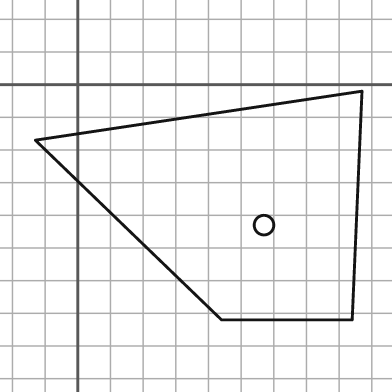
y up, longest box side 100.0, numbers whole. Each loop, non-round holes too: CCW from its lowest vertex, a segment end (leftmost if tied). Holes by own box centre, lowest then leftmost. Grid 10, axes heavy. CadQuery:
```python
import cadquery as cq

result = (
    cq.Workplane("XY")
    .moveTo(44.0, -72.0)
    .lineTo(84.0, -72.0)
    .lineTo(87.0, -2.0)
    .lineTo(-13.0, -17.0)
    .close()
    .moveTo(57.0, -43.0)
    .circle(3.0)
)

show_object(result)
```